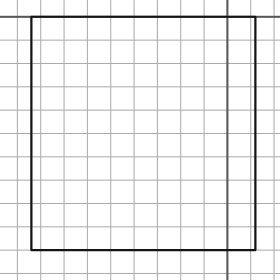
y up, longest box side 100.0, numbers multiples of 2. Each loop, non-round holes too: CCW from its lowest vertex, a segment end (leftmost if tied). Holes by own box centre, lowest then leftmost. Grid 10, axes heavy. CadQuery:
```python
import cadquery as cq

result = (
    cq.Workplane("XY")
    .moveTo(-84.0, -100.0)
    .lineTo(12.0, -100.0)
    .lineTo(12.0, 0.0)
    .lineTo(-84.0, 0.0)
    .close()
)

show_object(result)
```